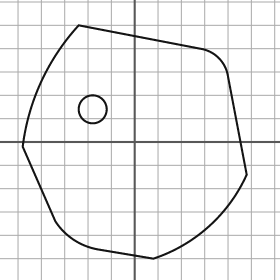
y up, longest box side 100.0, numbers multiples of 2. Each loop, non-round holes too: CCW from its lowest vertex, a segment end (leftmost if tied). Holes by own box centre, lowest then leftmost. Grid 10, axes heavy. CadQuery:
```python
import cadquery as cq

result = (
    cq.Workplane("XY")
    .moveTo(8.0, -50.0)
    .threePointArc((32.0, -36.0), (48.0, -14.0))
    .lineTo(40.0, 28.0)
    .threePointArc((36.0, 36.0), (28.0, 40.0))
    .lineTo(-24.0, 50.0)
    .threePointArc((-40.0, 26.0), (-48.0, -2.0))
    .lineTo(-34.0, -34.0)
    .threePointArc((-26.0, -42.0), (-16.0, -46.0))
    .close()
    .moveTo(-18.0, 14.0)
    .circle(6.0)
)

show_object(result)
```